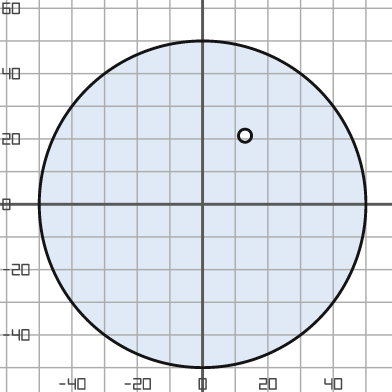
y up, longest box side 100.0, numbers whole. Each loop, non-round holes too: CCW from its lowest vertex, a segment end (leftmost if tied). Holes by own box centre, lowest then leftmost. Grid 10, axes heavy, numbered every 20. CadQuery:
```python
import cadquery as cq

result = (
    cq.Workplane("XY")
    .moveTo(0.0, 0.0)
    .circle(50.0)
    .moveTo(13.0, 21.0)
    .circle(2.0)
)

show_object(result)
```